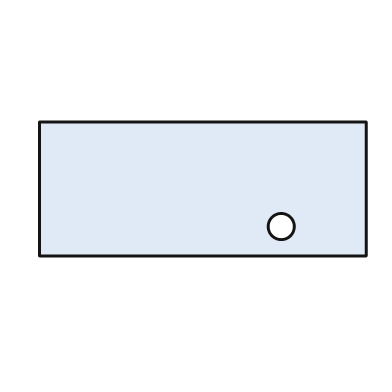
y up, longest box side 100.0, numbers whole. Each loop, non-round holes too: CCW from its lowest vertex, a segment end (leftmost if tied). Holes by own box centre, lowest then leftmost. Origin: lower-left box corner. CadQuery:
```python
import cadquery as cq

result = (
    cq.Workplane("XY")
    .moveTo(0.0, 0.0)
    .lineTo(100.0, 0.0)
    .lineTo(100.0, 41.0)
    .lineTo(0.0, 41.0)
    .close()
    .moveTo(74.0, 9.0)
    .circle(4.0)
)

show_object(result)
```